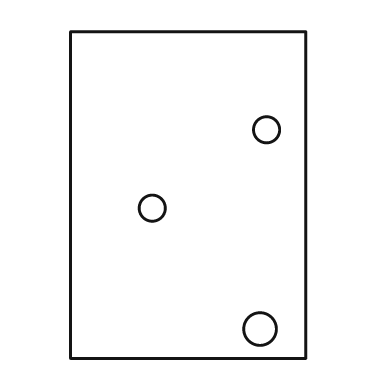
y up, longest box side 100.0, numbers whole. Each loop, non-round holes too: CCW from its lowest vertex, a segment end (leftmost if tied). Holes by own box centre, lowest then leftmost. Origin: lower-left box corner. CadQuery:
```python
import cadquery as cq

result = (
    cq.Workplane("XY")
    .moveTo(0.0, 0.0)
    .lineTo(72.0, 0.0)
    .lineTo(72.0, 100.0)
    .lineTo(0.0, 100.0)
    .close()
    .moveTo(58.0, 9.0)
    .circle(5.0)
    .moveTo(25.0, 46.0)
    .circle(4.0)
    .moveTo(60.0, 70.0)
    .circle(4.0)
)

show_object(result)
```